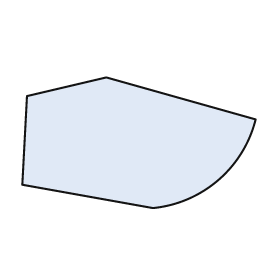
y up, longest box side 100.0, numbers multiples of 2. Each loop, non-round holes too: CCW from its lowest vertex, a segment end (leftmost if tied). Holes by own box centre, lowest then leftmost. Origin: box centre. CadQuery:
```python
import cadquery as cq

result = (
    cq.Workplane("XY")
    .moveTo(6.0, -28.0)
    .threePointArc((34.0, -16.0), (50.0, 10.0))
    .lineTo(-14.0, 28.0)
    .lineTo(-48.0, 20.0)
    .lineTo(-50.0, -18.0)
    .close()
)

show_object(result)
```